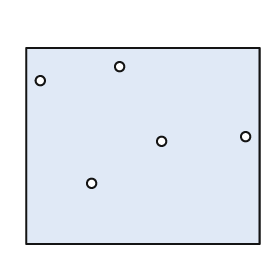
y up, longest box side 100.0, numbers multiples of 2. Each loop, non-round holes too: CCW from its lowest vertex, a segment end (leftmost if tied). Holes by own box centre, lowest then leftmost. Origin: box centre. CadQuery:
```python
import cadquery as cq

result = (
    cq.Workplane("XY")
    .moveTo(-50.0, -42.0)
    .lineTo(50.0, -42.0)
    .lineTo(50.0, 42.0)
    .lineTo(-50.0, 42.0)
    .close()
    .moveTo(-22.0, -16.0)
    .circle(2.0)
    .moveTo(8.0, 2.0)
    .circle(2.0)
    .moveTo(44.0, 4.0)
    .circle(2.0)
    .moveTo(-44.0, 28.0)
    .circle(2.0)
    .moveTo(-10.0, 34.0)
    .circle(2.0)
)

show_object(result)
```